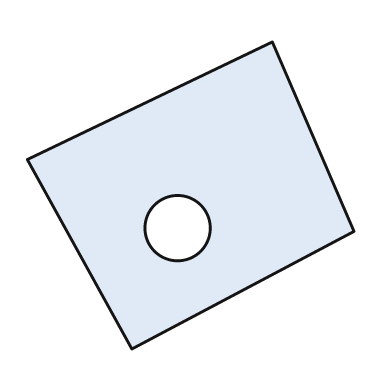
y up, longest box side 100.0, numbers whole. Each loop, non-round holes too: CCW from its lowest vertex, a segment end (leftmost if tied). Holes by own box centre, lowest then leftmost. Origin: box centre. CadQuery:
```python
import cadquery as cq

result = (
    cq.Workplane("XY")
    .moveTo(-18.0, -47.0)
    .lineTo(50.0, -11.0)
    .lineTo(25.0, 47.0)
    .lineTo(-50.0, 11.0)
    .close()
    .moveTo(-4.0, -10.0)
    .circle(10.0)
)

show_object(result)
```